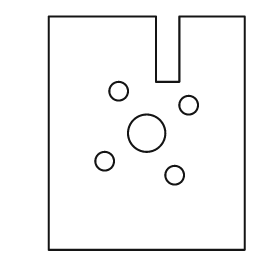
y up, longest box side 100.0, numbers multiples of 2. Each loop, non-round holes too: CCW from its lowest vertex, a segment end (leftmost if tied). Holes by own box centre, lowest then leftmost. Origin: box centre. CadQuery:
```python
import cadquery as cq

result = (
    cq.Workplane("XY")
    .moveTo(-42.0, -50.0)
    .lineTo(42.0, -50.0)
    .lineTo(42.0, 50.0)
    .lineTo(14.0, 50.0)
    .lineTo(14.0, 22.0)
    .lineTo(4.0, 22.0)
    .lineTo(4.0, 50.0)
    .lineTo(-42.0, 50.0)
    .close()
    .moveTo(12.0, -18.0)
    .circle(4.0)
    .moveTo(-18.0, -12.0)
    .circle(4.0)
    .moveTo(0.0, 0.0)
    .circle(8.0)
    .moveTo(18.0, 12.0)
    .circle(4.0)
    .moveTo(-12.0, 18.0)
    .circle(4.0)
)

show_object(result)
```